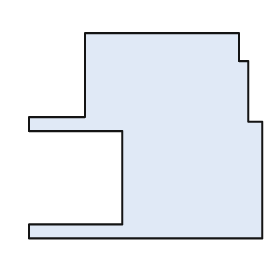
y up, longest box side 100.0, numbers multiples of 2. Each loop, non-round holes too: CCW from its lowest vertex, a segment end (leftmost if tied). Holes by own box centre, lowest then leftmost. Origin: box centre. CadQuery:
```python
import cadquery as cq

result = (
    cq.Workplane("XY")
    .moveTo(-50.0, -44.0)
    .lineTo(50.0, -44.0)
    .lineTo(50.0, 6.0)
    .lineTo(44.0, 6.0)
    .lineTo(44.0, 32.0)
    .lineTo(40.0, 32.0)
    .lineTo(40.0, 44.0)
    .lineTo(-26.0, 44.0)
    .lineTo(-26.0, 8.0)
    .lineTo(-50.0, 8.0)
    .lineTo(-50.0, 2.0)
    .lineTo(-10.0, 2.0)
    .lineTo(-10.0, -38.0)
    .lineTo(-50.0, -38.0)
    .close()
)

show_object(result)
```